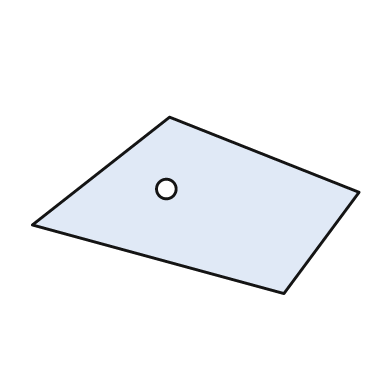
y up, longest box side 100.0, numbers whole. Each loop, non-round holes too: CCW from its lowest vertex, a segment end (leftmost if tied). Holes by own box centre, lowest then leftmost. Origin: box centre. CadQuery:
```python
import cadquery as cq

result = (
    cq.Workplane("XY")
    .moveTo(27.0, -27.0)
    .lineTo(50.0, 4.0)
    .lineTo(-8.0, 27.0)
    .lineTo(-50.0, -6.0)
    .close()
    .moveTo(-9.0, 5.0)
    .circle(3.0)
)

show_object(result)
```